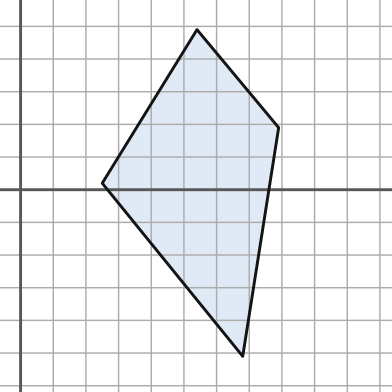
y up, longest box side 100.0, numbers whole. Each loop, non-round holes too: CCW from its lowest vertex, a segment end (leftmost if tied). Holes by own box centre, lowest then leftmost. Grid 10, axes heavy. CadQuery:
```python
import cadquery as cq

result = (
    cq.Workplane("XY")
    .moveTo(68.0, -51.0)
    .lineTo(79.0, 19.0)
    .lineTo(54.0, 49.0)
    .lineTo(25.0, 2.0)
    .close()
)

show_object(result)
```